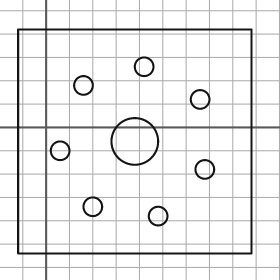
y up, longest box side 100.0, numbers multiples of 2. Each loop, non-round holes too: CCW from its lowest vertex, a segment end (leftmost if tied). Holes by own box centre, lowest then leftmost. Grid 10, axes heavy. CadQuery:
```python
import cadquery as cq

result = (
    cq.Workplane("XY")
    .moveTo(-12.0, -54.0)
    .lineTo(88.0, -54.0)
    .lineTo(88.0, 42.0)
    .lineTo(-12.0, 42.0)
    .close()
    .moveTo(48.0, -38.0)
    .circle(4.0)
    .moveTo(20.0, -34.0)
    .circle(4.0)
    .moveTo(68.0, -18.0)
    .circle(4.0)
    .moveTo(6.0, -10.0)
    .circle(4.0)
    .moveTo(38.0, -6.0)
    .circle(10.0)
    .moveTo(66.0, 12.0)
    .circle(4.0)
    .moveTo(16.0, 18.0)
    .circle(4.0)
    .moveTo(42.0, 26.0)
    .circle(4.0)
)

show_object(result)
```